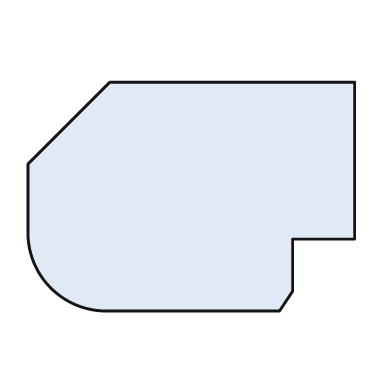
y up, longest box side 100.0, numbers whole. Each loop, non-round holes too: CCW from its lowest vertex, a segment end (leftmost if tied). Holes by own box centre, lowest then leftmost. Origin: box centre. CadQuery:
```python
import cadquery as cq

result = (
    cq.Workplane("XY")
    .moveTo(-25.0, -35.0)
    .lineTo(27.0, -35.0)
    .lineTo(31.0, -29.0)
    .lineTo(31.0, -13.0)
    .lineTo(50.0, -13.0)
    .lineTo(50.0, 35.0)
    .lineTo(-25.0, 35.0)
    .lineTo(-50.0, 10.0)
    .lineTo(-50.0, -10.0)
    .threePointArc((-43.0, -28.0), (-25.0, -35.0))
    .close()
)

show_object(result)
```